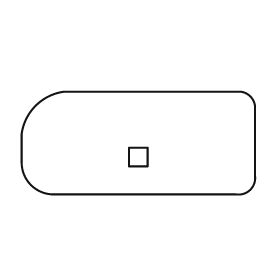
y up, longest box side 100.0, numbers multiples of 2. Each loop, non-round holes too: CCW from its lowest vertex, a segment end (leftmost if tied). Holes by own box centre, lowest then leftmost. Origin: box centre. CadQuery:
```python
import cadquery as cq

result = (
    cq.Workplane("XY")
    .moveTo(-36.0, -22.0)
    .lineTo(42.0, -22.0)
    .threePointArc((48.0, -20.0), (50.0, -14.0))
    .lineTo(50.0, 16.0)
    .threePointArc((48.0, 20.0), (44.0, 22.0))
    .lineTo(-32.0, 22.0)
    .threePointArc((-44.0, 16.0), (-50.0, 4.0))
    .lineTo(-50.0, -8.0)
    .threePointArc((-46.0, -18.0), (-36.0, -22.0))
    .close()
    .moveTo(-4.0, -10.0)
    .lineTo(4.0, -10.0)
    .lineTo(4.0, -2.0)
    .lineTo(-4.0, -2.0)
    .close()
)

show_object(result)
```